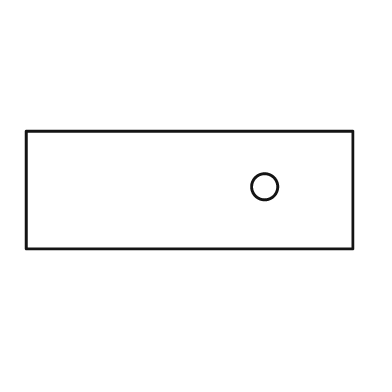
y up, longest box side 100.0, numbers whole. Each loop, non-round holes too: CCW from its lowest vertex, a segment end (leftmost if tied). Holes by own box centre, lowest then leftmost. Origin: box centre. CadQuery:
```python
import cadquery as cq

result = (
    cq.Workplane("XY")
    .moveTo(-50.0, -18.0)
    .lineTo(50.0, -18.0)
    .lineTo(50.0, 18.0)
    .lineTo(-50.0, 18.0)
    .close()
    .moveTo(23.0, 1.0)
    .circle(4.0)
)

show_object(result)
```